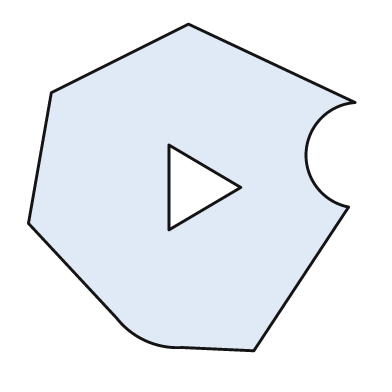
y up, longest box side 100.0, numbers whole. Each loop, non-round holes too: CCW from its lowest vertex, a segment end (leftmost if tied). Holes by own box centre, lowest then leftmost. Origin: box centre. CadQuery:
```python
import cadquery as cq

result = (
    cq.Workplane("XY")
    .moveTo(19.0, -50.0)
    .lineTo(48.0, -6.0)
    .threePointArc((35.0, 11.0), (50.0, 26.0))
    .lineTo(-1.0, 50.0)
    .lineTo(-43.0, 29.0)
    .lineTo(-50.0, -11.0)
    .lineTo(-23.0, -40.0)
    .threePointArc((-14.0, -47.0), (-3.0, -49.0))
    .close()
    .moveTo(-7.0, -13.0)
    .lineTo(15.0, 0.0)
    .lineTo(-7.0, 13.0)
    .close()
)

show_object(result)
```